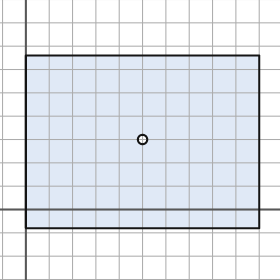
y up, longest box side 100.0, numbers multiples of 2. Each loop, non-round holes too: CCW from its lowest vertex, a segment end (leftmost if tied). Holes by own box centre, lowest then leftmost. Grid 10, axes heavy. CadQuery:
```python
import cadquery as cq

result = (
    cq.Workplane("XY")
    .moveTo(0.0, -8.0)
    .lineTo(100.0, -8.0)
    .lineTo(100.0, 66.0)
    .lineTo(0.0, 66.0)
    .close()
    .moveTo(50.0, 30.0)
    .circle(2.0)
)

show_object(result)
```